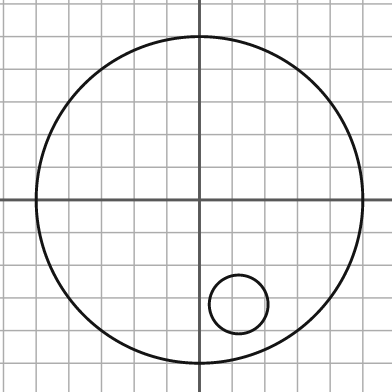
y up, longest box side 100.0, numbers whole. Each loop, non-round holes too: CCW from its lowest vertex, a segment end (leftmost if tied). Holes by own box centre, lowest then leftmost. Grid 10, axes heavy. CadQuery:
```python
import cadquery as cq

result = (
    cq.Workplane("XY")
    .moveTo(0.0, 0.0)
    .circle(50.0)
    .moveTo(12.0, -32.0)
    .circle(9.0)
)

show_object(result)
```